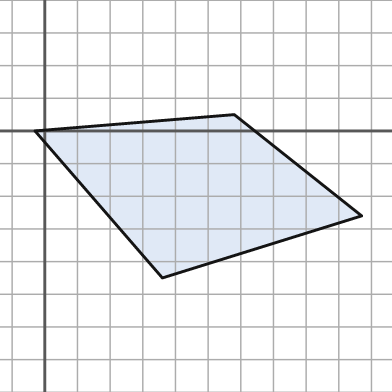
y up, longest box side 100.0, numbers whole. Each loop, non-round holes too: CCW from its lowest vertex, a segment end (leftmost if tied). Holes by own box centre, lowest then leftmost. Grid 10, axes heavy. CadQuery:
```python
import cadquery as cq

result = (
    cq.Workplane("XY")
    .moveTo(36.0, -45.0)
    .lineTo(97.0, -26.0)
    .lineTo(58.0, 5.0)
    .lineTo(-3.0, 0.0)
    .close()
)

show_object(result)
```